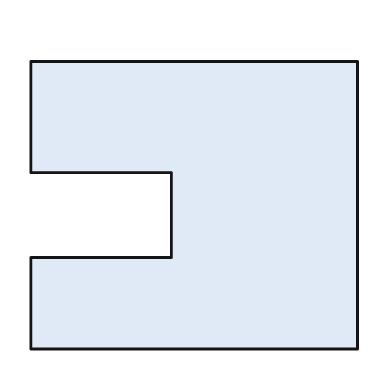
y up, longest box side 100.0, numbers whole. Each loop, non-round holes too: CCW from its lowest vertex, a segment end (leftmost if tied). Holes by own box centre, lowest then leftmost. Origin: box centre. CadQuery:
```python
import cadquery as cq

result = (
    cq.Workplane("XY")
    .moveTo(-50.0, -44.0)
    .lineTo(50.0, -44.0)
    .lineTo(50.0, 44.0)
    .lineTo(-50.0, 44.0)
    .lineTo(-50.0, 10.0)
    .lineTo(-7.0, 10.0)
    .lineTo(-7.0, -16.0)
    .lineTo(-50.0, -16.0)
    .close()
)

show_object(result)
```